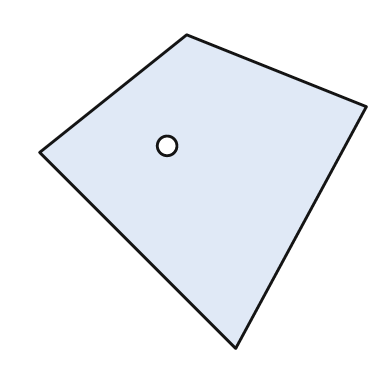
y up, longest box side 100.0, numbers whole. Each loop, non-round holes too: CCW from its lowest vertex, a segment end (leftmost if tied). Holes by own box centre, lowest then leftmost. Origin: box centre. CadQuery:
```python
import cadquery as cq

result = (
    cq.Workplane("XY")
    .moveTo(10.0, -48.0)
    .lineTo(50.0, 26.0)
    .lineTo(-5.0, 48.0)
    .lineTo(-50.0, 12.0)
    .close()
    .moveTo(-11.0, 14.0)
    .circle(3.0)
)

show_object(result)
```